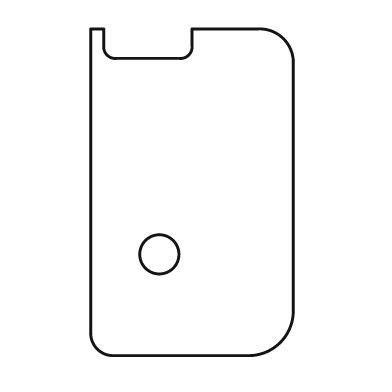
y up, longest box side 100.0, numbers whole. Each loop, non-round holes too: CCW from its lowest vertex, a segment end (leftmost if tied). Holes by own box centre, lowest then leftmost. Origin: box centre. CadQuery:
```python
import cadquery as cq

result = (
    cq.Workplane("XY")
    .moveTo(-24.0, -50.0)
    .lineTo(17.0, -50.0)
    .threePointArc((27.0, -46.0), (31.0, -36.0))
    .lineTo(31.0, 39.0)
    .threePointArc((28.0, 47.0), (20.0, 50.0))
    .lineTo(0.0, 50.0)
    .lineTo(0.0, 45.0)
    .threePointArc((-1.0, 42.0), (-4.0, 41.0))
    .lineTo(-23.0, 41.0)
    .threePointArc((-26.0, 42.0), (-27.0, 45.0))
    .lineTo(-27.0, 50.0)
    .lineTo(-31.0, 50.0)
    .lineTo(-31.0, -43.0)
    .threePointArc((-29.0, -48.0), (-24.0, -50.0))
    .close()
    .moveTo(-10.0, -19.0)
    .circle(6.0)
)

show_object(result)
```